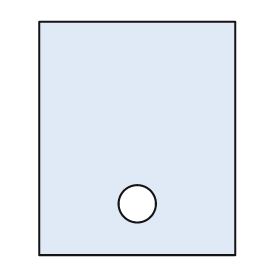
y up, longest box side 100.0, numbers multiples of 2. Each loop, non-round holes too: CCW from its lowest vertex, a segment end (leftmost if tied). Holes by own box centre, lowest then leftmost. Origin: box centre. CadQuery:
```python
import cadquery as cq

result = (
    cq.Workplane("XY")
    .moveTo(-42.0, -50.0)
    .lineTo(42.0, -50.0)
    .lineTo(42.0, 50.0)
    .lineTo(-42.0, 50.0)
    .close()
    .moveTo(0.0, -28.0)
    .circle(8.0)
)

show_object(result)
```